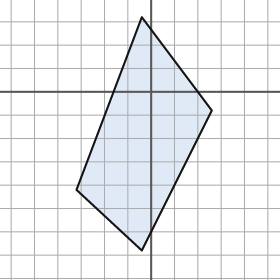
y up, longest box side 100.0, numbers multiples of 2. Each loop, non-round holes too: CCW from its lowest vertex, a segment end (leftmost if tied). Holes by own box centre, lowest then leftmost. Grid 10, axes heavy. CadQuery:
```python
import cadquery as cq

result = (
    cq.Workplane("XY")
    .moveTo(-4.0, -68.0)
    .lineTo(26.0, -8.0)
    .lineTo(-4.0, 32.0)
    .lineTo(-32.0, -42.0)
    .close()
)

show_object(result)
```